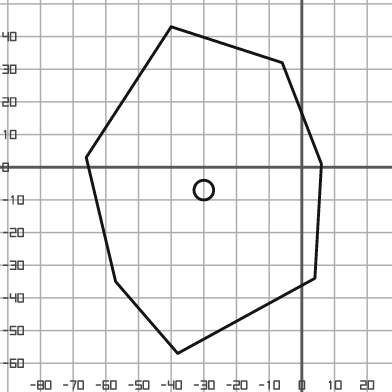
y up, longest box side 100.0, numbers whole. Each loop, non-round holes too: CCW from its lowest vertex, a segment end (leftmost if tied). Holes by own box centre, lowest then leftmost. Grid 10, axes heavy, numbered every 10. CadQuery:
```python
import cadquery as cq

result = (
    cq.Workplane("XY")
    .moveTo(-38.0, -57.0)
    .lineTo(4.0, -34.0)
    .lineTo(6.0, 1.0)
    .lineTo(-6.0, 32.0)
    .lineTo(-40.0, 43.0)
    .lineTo(-66.0, 3.0)
    .lineTo(-57.0, -35.0)
    .close()
    .moveTo(-30.0, -7.0)
    .circle(3.0)
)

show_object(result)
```